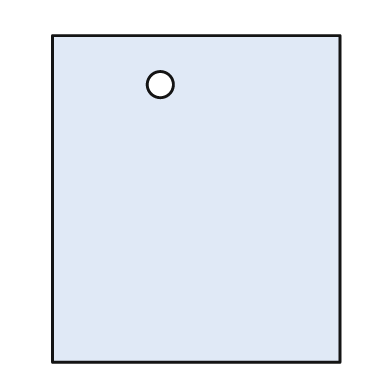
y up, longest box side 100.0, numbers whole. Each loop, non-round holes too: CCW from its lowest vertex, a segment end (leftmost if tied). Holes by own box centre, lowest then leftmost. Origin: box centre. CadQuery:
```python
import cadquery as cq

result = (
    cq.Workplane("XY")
    .moveTo(-44.0, -50.0)
    .lineTo(44.0, -50.0)
    .lineTo(44.0, 50.0)
    .lineTo(-44.0, 50.0)
    .close()
    .moveTo(-11.0, 35.0)
    .circle(4.0)
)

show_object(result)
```